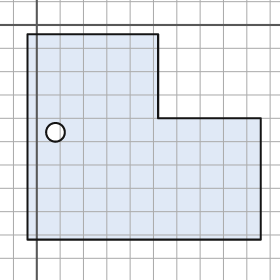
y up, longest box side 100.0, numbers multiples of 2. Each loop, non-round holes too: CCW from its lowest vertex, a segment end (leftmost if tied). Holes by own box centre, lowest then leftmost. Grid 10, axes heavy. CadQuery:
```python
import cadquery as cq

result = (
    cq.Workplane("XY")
    .moveTo(-4.0, -92.0)
    .lineTo(96.0, -92.0)
    .lineTo(96.0, -40.0)
    .lineTo(52.0, -40.0)
    .lineTo(52.0, -4.0)
    .lineTo(-4.0, -4.0)
    .close()
    .moveTo(8.0, -46.0)
    .circle(4.0)
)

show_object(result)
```